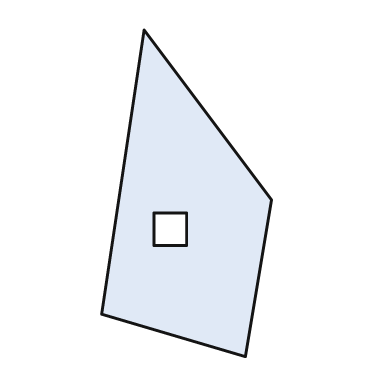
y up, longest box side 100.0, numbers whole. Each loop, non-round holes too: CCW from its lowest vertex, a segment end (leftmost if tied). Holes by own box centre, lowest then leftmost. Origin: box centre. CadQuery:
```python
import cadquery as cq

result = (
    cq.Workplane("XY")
    .moveTo(18.0, -50.0)
    .lineTo(26.0, -2.0)
    .lineTo(-13.0, 50.0)
    .lineTo(-26.0, -37.0)
    .close()
    .moveTo(-10.0, -16.0)
    .lineTo(0.0, -16.0)
    .lineTo(0.0, -6.0)
    .lineTo(-10.0, -6.0)
    .close()
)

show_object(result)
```